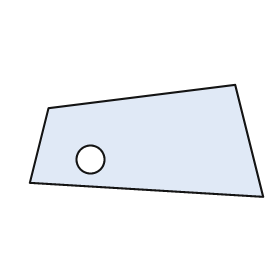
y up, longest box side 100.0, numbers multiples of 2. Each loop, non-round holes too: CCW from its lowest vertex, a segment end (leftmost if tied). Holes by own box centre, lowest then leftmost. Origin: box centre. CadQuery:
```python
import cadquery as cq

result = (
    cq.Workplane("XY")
    .moveTo(50.0, -24.0)
    .lineTo(38.0, 24.0)
    .lineTo(-42.0, 14.0)
    .lineTo(-50.0, -18.0)
    .close()
    .moveTo(-24.0, -8.0)
    .circle(6.0)
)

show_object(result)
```